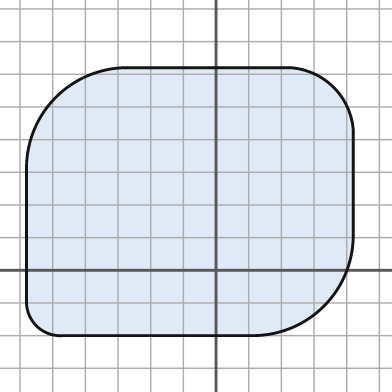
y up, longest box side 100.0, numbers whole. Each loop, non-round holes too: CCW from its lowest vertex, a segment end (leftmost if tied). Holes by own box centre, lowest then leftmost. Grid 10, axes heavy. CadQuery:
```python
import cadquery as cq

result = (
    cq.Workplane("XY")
    .moveTo(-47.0, -20.0)
    .lineTo(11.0, -20.0)
    .threePointArc((33.0, -11.0), (42.0, 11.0))
    .lineTo(42.0, 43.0)
    .threePointArc((36.0, 56.0), (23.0, 62.0))
    .lineTo(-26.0, 62.0)
    .threePointArc((-49.0, 53.0), (-58.0, 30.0))
    .lineTo(-58.0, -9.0)
    .threePointArc((-55.0, -17.0), (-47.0, -20.0))
    .close()
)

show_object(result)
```